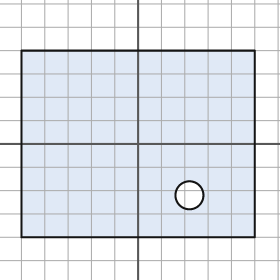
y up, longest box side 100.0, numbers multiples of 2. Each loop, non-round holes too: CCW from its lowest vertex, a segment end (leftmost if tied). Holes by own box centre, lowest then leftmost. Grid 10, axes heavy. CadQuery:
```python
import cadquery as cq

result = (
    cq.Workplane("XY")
    .moveTo(-50.0, -40.0)
    .lineTo(50.0, -40.0)
    .lineTo(50.0, 40.0)
    .lineTo(-50.0, 40.0)
    .close()
    .moveTo(22.0, -22.0)
    .circle(6.0)
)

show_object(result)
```